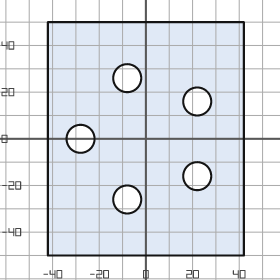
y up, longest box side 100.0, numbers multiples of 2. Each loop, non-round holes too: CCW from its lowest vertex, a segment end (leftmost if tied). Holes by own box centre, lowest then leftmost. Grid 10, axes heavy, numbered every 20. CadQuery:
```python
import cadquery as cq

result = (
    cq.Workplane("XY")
    .moveTo(-42.0, -50.0)
    .lineTo(42.0, -50.0)
    .lineTo(42.0, 50.0)
    .lineTo(-42.0, 50.0)
    .close()
    .moveTo(-8.0, -26.0)
    .circle(6.0)
    .moveTo(22.0, -16.0)
    .circle(6.0)
    .moveTo(-28.0, 0.0)
    .circle(6.0)
    .moveTo(22.0, 16.0)
    .circle(6.0)
    .moveTo(-8.0, 26.0)
    .circle(6.0)
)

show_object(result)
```